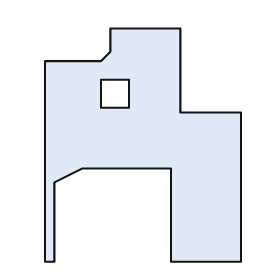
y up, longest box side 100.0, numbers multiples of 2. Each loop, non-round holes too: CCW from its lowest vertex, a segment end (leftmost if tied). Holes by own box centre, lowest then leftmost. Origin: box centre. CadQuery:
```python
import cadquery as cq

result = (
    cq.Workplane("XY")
    .moveTo(-42.0, -50.0)
    .lineTo(-38.0, -50.0)
    .lineTo(-38.0, -16.0)
    .lineTo(-26.0, -10.0)
    .lineTo(12.0, -10.0)
    .lineTo(12.0, -50.0)
    .lineTo(42.0, -50.0)
    .lineTo(42.0, 14.0)
    .lineTo(16.0, 14.0)
    .lineTo(16.0, 50.0)
    .lineTo(-14.0, 50.0)
    .lineTo(-14.0, 40.0)
    .lineTo(-18.0, 36.0)
    .lineTo(-42.0, 36.0)
    .close()
    .moveTo(-18.0, 16.0)
    .lineTo(-6.0, 16.0)
    .lineTo(-6.0, 28.0)
    .lineTo(-18.0, 28.0)
    .close()
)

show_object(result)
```